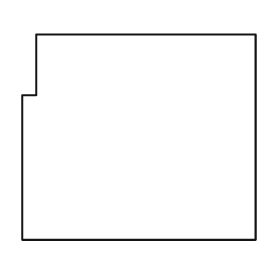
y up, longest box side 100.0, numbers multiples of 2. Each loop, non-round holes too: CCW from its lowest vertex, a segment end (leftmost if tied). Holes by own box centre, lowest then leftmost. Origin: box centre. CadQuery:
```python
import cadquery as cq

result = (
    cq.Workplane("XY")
    .moveTo(-50.0, -44.0)
    .lineTo(50.0, -44.0)
    .lineTo(50.0, 44.0)
    .lineTo(-44.0, 44.0)
    .lineTo(-44.0, 18.0)
    .lineTo(-50.0, 18.0)
    .close()
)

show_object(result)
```